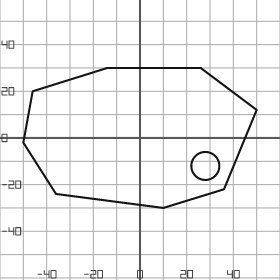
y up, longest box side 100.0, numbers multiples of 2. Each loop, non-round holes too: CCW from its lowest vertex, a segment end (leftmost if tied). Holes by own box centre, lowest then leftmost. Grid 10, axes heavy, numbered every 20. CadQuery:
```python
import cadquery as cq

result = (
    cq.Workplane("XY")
    .moveTo(10.0, -30.0)
    .lineTo(36.0, -22.0)
    .lineTo(50.0, 12.0)
    .lineTo(26.0, 30.0)
    .lineTo(-14.0, 30.0)
    .lineTo(-46.0, 20.0)
    .lineTo(-50.0, -2.0)
    .lineTo(-36.0, -24.0)
    .close()
    .moveTo(28.0, -12.0)
    .circle(6.0)
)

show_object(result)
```